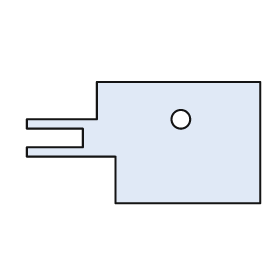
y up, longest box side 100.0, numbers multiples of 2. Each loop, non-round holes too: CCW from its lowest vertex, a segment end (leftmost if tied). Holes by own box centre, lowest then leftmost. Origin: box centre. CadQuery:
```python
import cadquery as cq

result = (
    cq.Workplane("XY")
    .moveTo(-12.0, -26.0)
    .lineTo(50.0, -26.0)
    .lineTo(50.0, 26.0)
    .lineTo(-20.0, 26.0)
    .lineTo(-20.0, 10.0)
    .lineTo(-50.0, 10.0)
    .lineTo(-50.0, 6.0)
    .lineTo(-26.0, 6.0)
    .lineTo(-26.0, -2.0)
    .lineTo(-50.0, -2.0)
    .lineTo(-50.0, -6.0)
    .lineTo(-12.0, -6.0)
    .close()
    .moveTo(16.0, 10.0)
    .circle(4.0)
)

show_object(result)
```